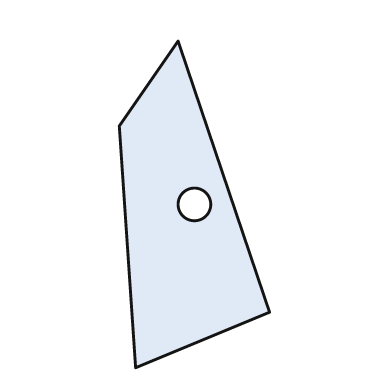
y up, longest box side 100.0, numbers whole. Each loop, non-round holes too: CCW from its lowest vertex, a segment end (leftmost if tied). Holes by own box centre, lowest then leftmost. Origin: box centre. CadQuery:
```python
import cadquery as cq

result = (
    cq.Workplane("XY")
    .moveTo(-18.0, -50.0)
    .lineTo(23.0, -33.0)
    .lineTo(-5.0, 50.0)
    .lineTo(-23.0, 24.0)
    .close()
    .moveTo(0.0, 0.0)
    .circle(5.0)
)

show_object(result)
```